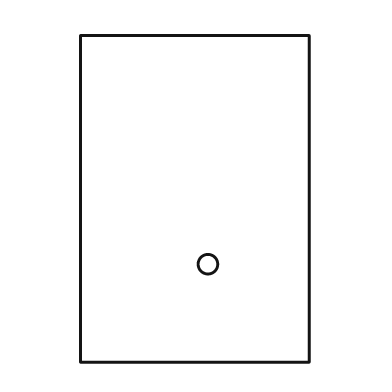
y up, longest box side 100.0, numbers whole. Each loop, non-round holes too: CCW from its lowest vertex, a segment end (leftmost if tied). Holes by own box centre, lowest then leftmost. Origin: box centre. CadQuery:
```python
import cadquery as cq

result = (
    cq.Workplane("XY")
    .moveTo(-35.0, -50.0)
    .lineTo(35.0, -50.0)
    .lineTo(35.0, 50.0)
    .lineTo(-35.0, 50.0)
    .close()
    .moveTo(4.0, -20.0)
    .circle(3.0)
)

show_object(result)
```